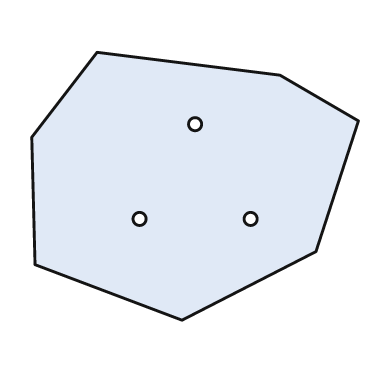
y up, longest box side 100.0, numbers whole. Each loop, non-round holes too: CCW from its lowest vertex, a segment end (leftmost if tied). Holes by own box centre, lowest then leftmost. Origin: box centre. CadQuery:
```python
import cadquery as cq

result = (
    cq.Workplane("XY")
    .moveTo(-4.0, -41.0)
    .lineTo(37.0, -20.0)
    .lineTo(50.0, 20.0)
    .lineTo(26.0, 34.0)
    .lineTo(-30.0, 41.0)
    .lineTo(-50.0, 15.0)
    .lineTo(-49.0, -24.0)
    .close()
    .moveTo(-17.0, -10.0)
    .circle(2.0)
    .moveTo(17.0, -10.0)
    .circle(2.0)
    .moveTo(0.0, 19.0)
    .circle(2.0)
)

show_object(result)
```